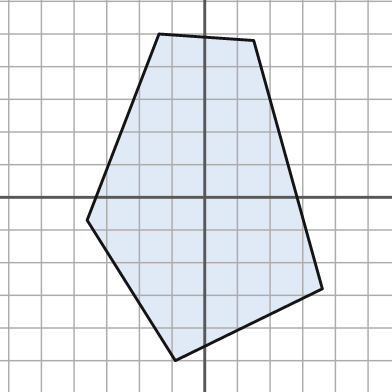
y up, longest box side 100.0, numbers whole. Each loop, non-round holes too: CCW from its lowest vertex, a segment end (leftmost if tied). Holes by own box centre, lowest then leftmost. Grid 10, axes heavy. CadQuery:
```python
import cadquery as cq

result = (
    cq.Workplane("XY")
    .moveTo(-9.0, -50.0)
    .lineTo(36.0, -28.0)
    .lineTo(15.0, 48.0)
    .lineTo(-14.0, 50.0)
    .lineTo(-36.0, -7.0)
    .close()
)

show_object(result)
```